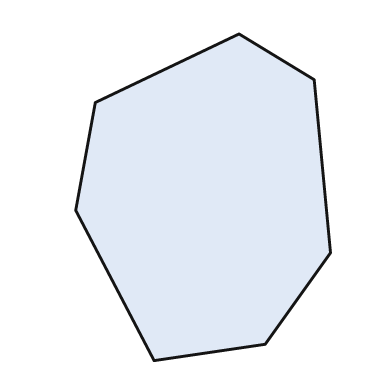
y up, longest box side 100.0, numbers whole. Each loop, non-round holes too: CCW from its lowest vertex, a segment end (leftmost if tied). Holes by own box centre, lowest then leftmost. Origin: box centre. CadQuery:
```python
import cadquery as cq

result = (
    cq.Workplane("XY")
    .moveTo(-15.0, -50.0)
    .lineTo(19.0, -45.0)
    .lineTo(39.0, -17.0)
    .lineTo(34.0, 36.0)
    .lineTo(11.0, 50.0)
    .lineTo(-33.0, 29.0)
    .lineTo(-39.0, -4.0)
    .close()
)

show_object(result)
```